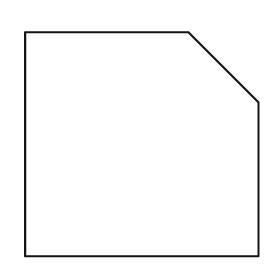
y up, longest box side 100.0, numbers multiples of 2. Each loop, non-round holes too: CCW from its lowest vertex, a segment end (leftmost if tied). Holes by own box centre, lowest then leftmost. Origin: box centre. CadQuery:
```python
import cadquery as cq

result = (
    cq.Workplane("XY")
    .moveTo(-50.0, -48.0)
    .lineTo(50.0, -48.0)
    .lineTo(50.0, 18.0)
    .lineTo(20.0, 48.0)
    .lineTo(-50.0, 48.0)
    .close()
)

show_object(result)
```